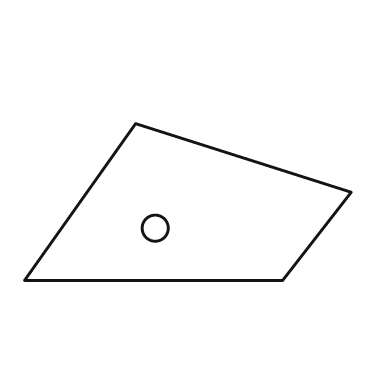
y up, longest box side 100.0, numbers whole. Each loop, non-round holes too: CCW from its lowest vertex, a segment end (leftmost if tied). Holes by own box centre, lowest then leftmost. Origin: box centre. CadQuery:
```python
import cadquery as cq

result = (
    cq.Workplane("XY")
    .moveTo(-50.0, -24.0)
    .lineTo(29.0, -24.0)
    .lineTo(50.0, 3.0)
    .lineTo(-16.0, 24.0)
    .close()
    .moveTo(-10.0, -8.0)
    .circle(4.0)
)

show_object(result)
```